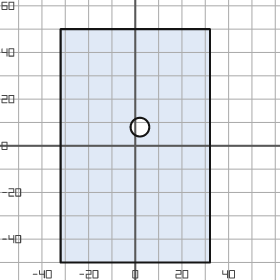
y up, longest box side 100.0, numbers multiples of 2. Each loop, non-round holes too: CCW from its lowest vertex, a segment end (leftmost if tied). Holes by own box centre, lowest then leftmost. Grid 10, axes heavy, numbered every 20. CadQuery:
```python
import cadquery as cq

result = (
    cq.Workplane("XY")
    .moveTo(-32.0, -50.0)
    .lineTo(32.0, -50.0)
    .lineTo(32.0, 50.0)
    .lineTo(-32.0, 50.0)
    .close()
    .moveTo(2.0, 8.0)
    .circle(4.0)
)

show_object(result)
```